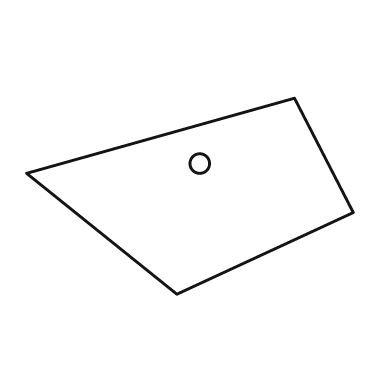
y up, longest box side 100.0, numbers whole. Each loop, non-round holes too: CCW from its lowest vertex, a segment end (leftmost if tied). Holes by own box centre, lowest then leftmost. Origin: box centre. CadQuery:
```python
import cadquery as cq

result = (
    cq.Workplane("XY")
    .moveTo(-4.0, -30.0)
    .lineTo(50.0, -5.0)
    .lineTo(32.0, 30.0)
    .lineTo(-50.0, 7.0)
    .close()
    .moveTo(3.0, 10.0)
    .circle(3.0)
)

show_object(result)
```